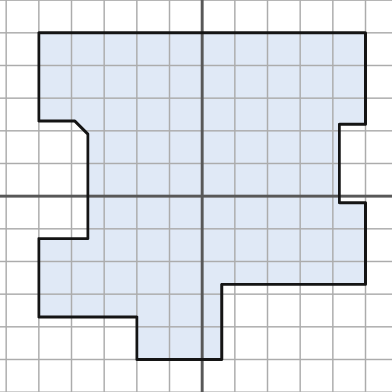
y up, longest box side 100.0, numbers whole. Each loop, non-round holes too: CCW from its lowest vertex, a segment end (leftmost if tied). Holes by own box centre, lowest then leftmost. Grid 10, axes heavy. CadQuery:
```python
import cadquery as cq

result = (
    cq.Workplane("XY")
    .moveTo(-20.0, -50.0)
    .lineTo(6.0, -50.0)
    .lineTo(6.0, -27.0)
    .lineTo(50.0, -27.0)
    .lineTo(50.0, -2.0)
    .lineTo(42.0, -2.0)
    .lineTo(42.0, 22.0)
    .lineTo(50.0, 22.0)
    .lineTo(50.0, 50.0)
    .lineTo(-50.0, 50.0)
    .lineTo(-50.0, 23.0)
    .lineTo(-39.0, 23.0)
    .lineTo(-35.0, 19.0)
    .lineTo(-35.0, -13.0)
    .lineTo(-50.0, -13.0)
    .lineTo(-50.0, -37.0)
    .lineTo(-20.0, -37.0)
    .close()
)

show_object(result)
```